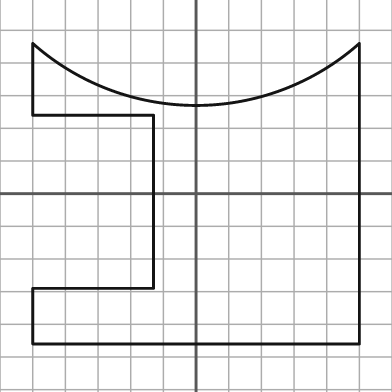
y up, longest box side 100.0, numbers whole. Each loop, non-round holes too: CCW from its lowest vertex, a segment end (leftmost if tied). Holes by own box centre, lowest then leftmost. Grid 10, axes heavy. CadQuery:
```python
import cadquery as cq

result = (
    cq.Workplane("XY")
    .moveTo(-50.0, -46.0)
    .lineTo(50.0, -46.0)
    .lineTo(50.0, 46.0)
    .threePointArc((0.0, 27.0), (-50.0, 46.0))
    .lineTo(-50.0, 24.0)
    .lineTo(-13.0, 24.0)
    .lineTo(-13.0, -29.0)
    .lineTo(-50.0, -29.0)
    .close()
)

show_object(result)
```